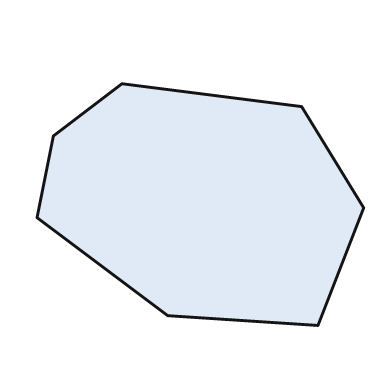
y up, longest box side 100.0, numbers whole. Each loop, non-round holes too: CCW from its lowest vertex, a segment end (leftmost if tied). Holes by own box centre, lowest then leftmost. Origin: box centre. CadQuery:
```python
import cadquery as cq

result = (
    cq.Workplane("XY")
    .moveTo(36.0, -37.0)
    .lineTo(50.0, -1.0)
    .lineTo(31.0, 30.0)
    .lineTo(-24.0, 37.0)
    .lineTo(-45.0, 21.0)
    .lineTo(-50.0, -4.0)
    .lineTo(-10.0, -34.0)
    .close()
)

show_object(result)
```